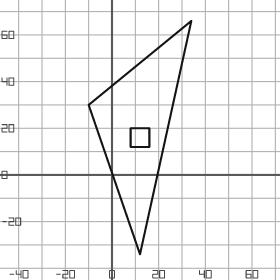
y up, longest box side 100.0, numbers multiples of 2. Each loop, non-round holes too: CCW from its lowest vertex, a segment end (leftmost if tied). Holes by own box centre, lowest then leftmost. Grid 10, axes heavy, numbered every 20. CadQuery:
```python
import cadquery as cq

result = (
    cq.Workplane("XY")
    .moveTo(12.0, -34.0)
    .lineTo(34.0, 66.0)
    .lineTo(-10.0, 30.0)
    .close()
    .moveTo(8.0, 12.0)
    .lineTo(16.0, 12.0)
    .lineTo(16.0, 20.0)
    .lineTo(8.0, 20.0)
    .close()
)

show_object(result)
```